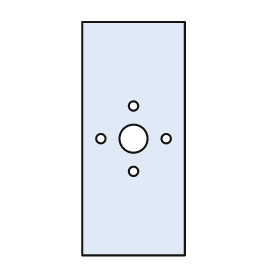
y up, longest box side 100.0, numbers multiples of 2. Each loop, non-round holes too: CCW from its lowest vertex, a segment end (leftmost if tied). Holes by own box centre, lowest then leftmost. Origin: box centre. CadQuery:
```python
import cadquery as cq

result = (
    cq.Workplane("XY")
    .moveTo(-22.0, -50.0)
    .lineTo(22.0, -50.0)
    .lineTo(22.0, 50.0)
    .lineTo(-22.0, 50.0)
    .close()
    .moveTo(0.0, -14.0)
    .circle(2.0)
    .moveTo(-14.0, 0.0)
    .circle(2.0)
    .moveTo(0.0, 0.0)
    .circle(6.0)
    .moveTo(14.0, 0.0)
    .circle(2.0)
    .moveTo(0.0, 14.0)
    .circle(2.0)
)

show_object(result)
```